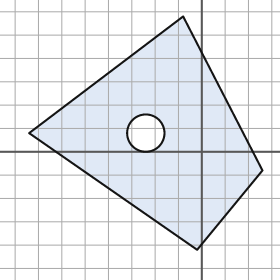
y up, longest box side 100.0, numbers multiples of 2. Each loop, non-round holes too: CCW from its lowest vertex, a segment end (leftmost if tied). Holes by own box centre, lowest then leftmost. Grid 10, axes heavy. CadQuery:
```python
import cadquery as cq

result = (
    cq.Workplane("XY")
    .moveTo(-2.0, -42.0)
    .lineTo(26.0, -8.0)
    .lineTo(-8.0, 58.0)
    .lineTo(-74.0, 8.0)
    .close()
    .moveTo(-24.0, 8.0)
    .circle(8.0)
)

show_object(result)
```